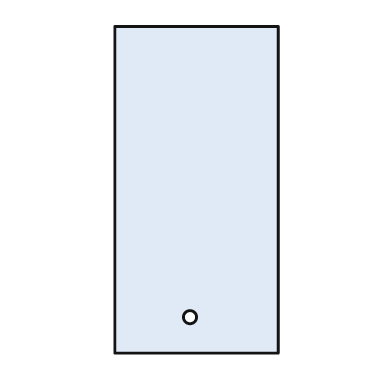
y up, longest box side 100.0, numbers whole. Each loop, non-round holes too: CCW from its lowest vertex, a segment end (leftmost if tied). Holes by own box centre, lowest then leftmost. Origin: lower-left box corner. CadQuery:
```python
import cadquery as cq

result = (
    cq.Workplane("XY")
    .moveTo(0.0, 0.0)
    .lineTo(50.0, 0.0)
    .lineTo(50.0, 100.0)
    .lineTo(0.0, 100.0)
    .close()
    .moveTo(23.0, 11.0)
    .circle(2.0)
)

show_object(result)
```